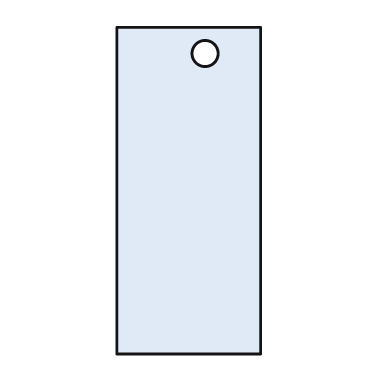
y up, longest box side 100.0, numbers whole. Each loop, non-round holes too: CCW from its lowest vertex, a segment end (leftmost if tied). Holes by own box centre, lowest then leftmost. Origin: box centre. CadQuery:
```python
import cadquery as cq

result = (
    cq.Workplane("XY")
    .moveTo(-22.0, -50.0)
    .lineTo(22.0, -50.0)
    .lineTo(22.0, 50.0)
    .lineTo(-22.0, 50.0)
    .close()
    .moveTo(5.0, 42.0)
    .circle(4.0)
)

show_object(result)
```